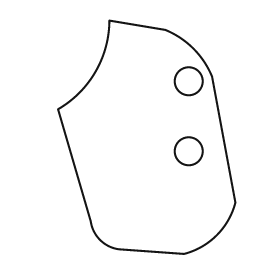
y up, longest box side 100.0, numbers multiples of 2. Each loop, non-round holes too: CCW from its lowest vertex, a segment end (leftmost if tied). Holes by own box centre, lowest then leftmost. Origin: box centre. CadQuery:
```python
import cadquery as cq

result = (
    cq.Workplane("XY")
    .moveTo(16.0, -50.0)
    .threePointArc((30.0, -42.0), (38.0, -28.0))
    .lineTo(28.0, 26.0)
    .threePointArc((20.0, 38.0), (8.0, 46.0))
    .lineTo(-16.0, 50.0)
    .threePointArc((-22.0, 28.0), (-38.0, 12.0))
    .lineTo(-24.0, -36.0)
    .threePointArc((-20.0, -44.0), (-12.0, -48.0))
    .close()
    .moveTo(18.0, -6.0)
    .circle(6.0)
    .moveTo(18.0, 24.0)
    .circle(6.0)
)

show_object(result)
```